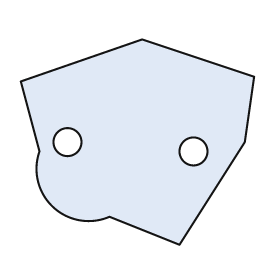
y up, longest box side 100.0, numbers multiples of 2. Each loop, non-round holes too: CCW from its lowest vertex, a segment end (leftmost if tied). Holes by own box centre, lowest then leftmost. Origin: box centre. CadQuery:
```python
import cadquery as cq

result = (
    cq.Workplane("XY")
    .moveTo(18.0, -44.0)
    .lineTo(46.0, 0.0)
    .lineTo(50.0, 28.0)
    .lineTo(2.0, 44.0)
    .lineTo(-50.0, 26.0)
    .lineTo(-42.0, -4.0)
    .threePointArc((-36.0, -28.0), (-12.0, -32.0))
    .close()
    .moveTo(24.0, -4.0)
    .circle(6.0)
    .moveTo(-30.0, 0.0)
    .circle(6.0)
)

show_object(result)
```